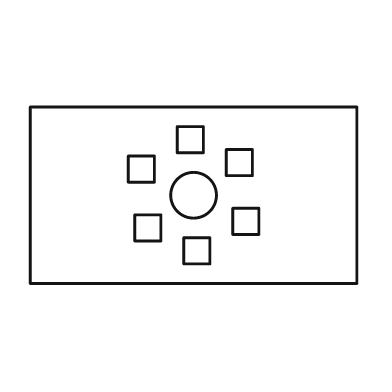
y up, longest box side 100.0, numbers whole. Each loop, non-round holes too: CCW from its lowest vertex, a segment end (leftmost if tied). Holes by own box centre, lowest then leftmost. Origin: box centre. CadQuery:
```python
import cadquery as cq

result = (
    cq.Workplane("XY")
    .moveTo(-50.0, -27.0)
    .lineTo(50.0, -27.0)
    .lineTo(50.0, 27.0)
    .lineTo(-50.0, 27.0)
    .close()
    .moveTo(-3.0, -21.0)
    .lineTo(5.0, -21.0)
    .lineTo(5.0, -13.0)
    .lineTo(-3.0, -13.0)
    .close()
    .moveTo(-18.0, -14.0)
    .lineTo(-10.0, -14.0)
    .lineTo(-10.0, -6.0)
    .lineTo(-18.0, -6.0)
    .close()
    .moveTo(12.0, -12.0)
    .lineTo(20.0, -12.0)
    .lineTo(20.0, -4.0)
    .lineTo(12.0, -4.0)
    .close()
    .moveTo(0.0, 0.0)
    .circle(7.0)
    .moveTo(-20.0, 4.0)
    .lineTo(-12.0, 4.0)
    .lineTo(-12.0, 12.0)
    .lineTo(-20.0, 12.0)
    .close()
    .moveTo(10.0, 6.0)
    .lineTo(18.0, 6.0)
    .lineTo(18.0, 14.0)
    .lineTo(10.0, 14.0)
    .close()
    .moveTo(-5.0, 13.0)
    .lineTo(3.0, 13.0)
    .lineTo(3.0, 21.0)
    .lineTo(-5.0, 21.0)
    .close()
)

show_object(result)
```